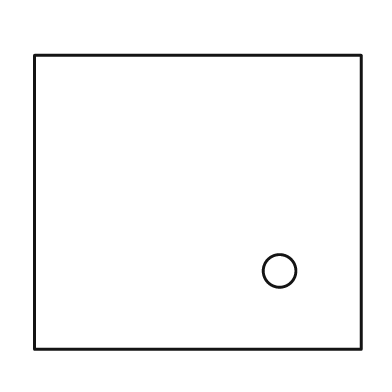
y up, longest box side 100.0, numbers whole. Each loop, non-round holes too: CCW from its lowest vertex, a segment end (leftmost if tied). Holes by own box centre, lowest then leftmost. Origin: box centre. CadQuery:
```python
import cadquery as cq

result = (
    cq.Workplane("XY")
    .moveTo(-50.0, -45.0)
    .lineTo(50.0, -45.0)
    .lineTo(50.0, 45.0)
    .lineTo(-50.0, 45.0)
    .close()
    .moveTo(25.0, -21.0)
    .circle(5.0)
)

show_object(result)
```